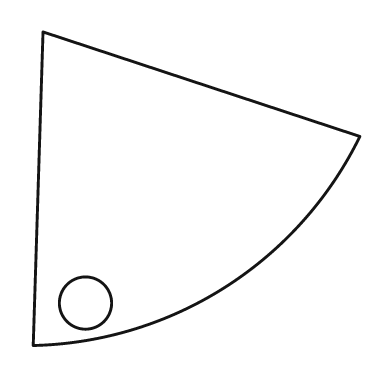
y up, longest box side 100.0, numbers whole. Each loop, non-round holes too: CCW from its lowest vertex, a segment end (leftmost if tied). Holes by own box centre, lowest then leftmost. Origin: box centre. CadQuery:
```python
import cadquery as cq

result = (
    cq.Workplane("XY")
    .moveTo(-50.0, -48.0)
    .threePointArc((9.0, -30.0), (50.0, 16.0))
    .lineTo(-47.0, 48.0)
    .close()
    .moveTo(-34.0, -35.0)
    .circle(8.0)
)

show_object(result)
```